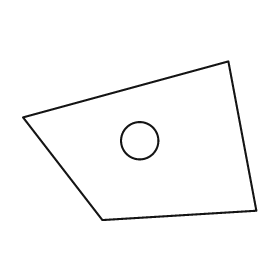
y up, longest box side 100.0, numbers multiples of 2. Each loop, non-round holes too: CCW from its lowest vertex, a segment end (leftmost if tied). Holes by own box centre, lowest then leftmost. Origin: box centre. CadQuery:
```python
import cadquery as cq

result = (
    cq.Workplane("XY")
    .moveTo(-16.0, -34.0)
    .lineTo(50.0, -30.0)
    .lineTo(38.0, 34.0)
    .lineTo(-50.0, 10.0)
    .close()
    .moveTo(0.0, 0.0)
    .circle(8.0)
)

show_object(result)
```